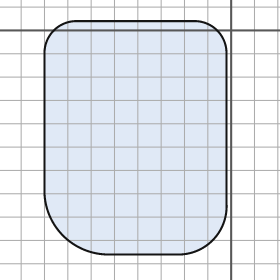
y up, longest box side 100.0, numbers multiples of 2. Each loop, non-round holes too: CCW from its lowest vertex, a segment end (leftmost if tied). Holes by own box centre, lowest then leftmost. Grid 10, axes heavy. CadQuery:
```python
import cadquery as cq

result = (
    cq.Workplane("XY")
    .moveTo(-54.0, -96.0)
    .lineTo(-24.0, -96.0)
    .threePointArc((-8.0, -90.0), (-2.0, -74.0))
    .lineTo(-2.0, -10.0)
    .threePointArc((-6.0, 0.0), (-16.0, 4.0))
    .lineTo(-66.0, 4.0)
    .threePointArc((-76.0, 0.0), (-80.0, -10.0))
    .lineTo(-80.0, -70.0)
    .threePointArc((-72.0, -88.0), (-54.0, -96.0))
    .close()
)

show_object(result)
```